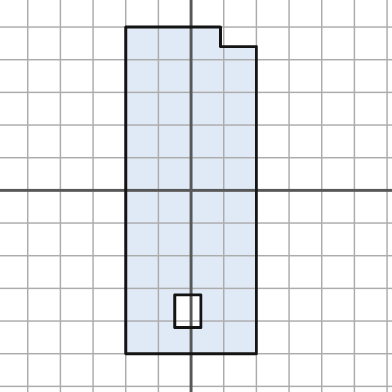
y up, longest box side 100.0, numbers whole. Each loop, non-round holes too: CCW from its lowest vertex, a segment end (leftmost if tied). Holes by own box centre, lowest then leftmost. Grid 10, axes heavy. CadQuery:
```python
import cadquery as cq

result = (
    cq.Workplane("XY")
    .moveTo(-20.0, -50.0)
    .lineTo(20.0, -50.0)
    .lineTo(20.0, 44.0)
    .lineTo(9.0, 44.0)
    .lineTo(9.0, 50.0)
    .lineTo(-20.0, 50.0)
    .close()
    .moveTo(-5.0, -42.0)
    .lineTo(3.0, -42.0)
    .lineTo(3.0, -32.0)
    .lineTo(-5.0, -32.0)
    .close()
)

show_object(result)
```